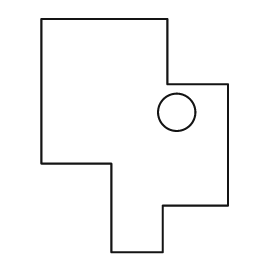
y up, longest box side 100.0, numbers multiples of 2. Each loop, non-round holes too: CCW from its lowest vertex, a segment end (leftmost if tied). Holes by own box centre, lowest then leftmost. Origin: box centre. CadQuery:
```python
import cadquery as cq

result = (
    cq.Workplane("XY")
    .moveTo(-10.0, -50.0)
    .lineTo(12.0, -50.0)
    .lineTo(12.0, -30.0)
    .lineTo(40.0, -30.0)
    .lineTo(40.0, 22.0)
    .lineTo(14.0, 22.0)
    .lineTo(14.0, 50.0)
    .lineTo(-40.0, 50.0)
    .lineTo(-40.0, -12.0)
    .lineTo(-10.0, -12.0)
    .close()
    .moveTo(18.0, 10.0)
    .circle(8.0)
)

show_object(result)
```